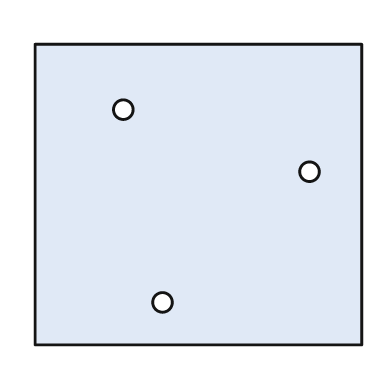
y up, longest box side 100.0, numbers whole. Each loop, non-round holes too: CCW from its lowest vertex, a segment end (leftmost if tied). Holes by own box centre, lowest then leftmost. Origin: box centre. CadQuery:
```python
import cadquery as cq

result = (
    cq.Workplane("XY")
    .moveTo(-50.0, -46.0)
    .lineTo(50.0, -46.0)
    .lineTo(50.0, 46.0)
    .lineTo(-50.0, 46.0)
    .close()
    .moveTo(-11.0, -33.0)
    .circle(3.0)
    .moveTo(34.0, 7.0)
    .circle(3.0)
    .moveTo(-23.0, 26.0)
    .circle(3.0)
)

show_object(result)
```